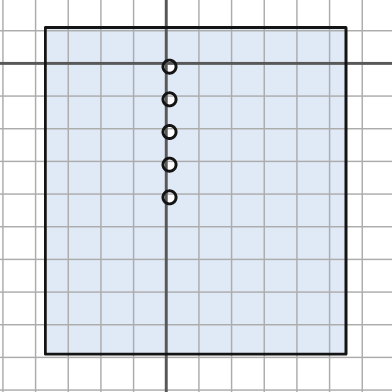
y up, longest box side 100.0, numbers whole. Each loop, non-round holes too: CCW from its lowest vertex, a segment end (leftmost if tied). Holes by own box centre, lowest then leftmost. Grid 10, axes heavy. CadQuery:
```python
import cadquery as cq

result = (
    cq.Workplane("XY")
    .moveTo(-37.0, -89.0)
    .lineTo(55.0, -89.0)
    .lineTo(55.0, 11.0)
    .lineTo(-37.0, 11.0)
    .close()
    .moveTo(1.0, -41.0)
    .circle(2.0)
    .moveTo(1.0, -31.0)
    .circle(2.0)
    .moveTo(1.0, -21.0)
    .circle(2.0)
    .moveTo(1.0, -11.0)
    .circle(2.0)
    .moveTo(1.0, -1.0)
    .circle(2.0)
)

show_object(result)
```